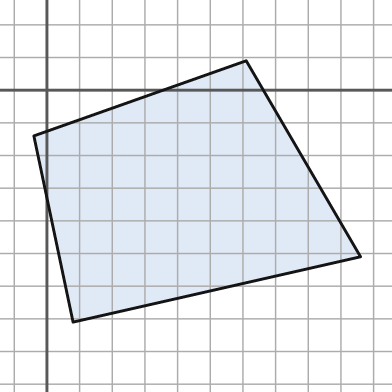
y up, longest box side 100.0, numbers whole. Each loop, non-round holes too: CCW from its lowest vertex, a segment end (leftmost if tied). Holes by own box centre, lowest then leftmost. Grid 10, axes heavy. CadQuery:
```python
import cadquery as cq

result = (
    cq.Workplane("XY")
    .moveTo(8.0, -71.0)
    .lineTo(96.0, -51.0)
    .lineTo(61.0, 9.0)
    .lineTo(-4.0, -14.0)
    .close()
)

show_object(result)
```